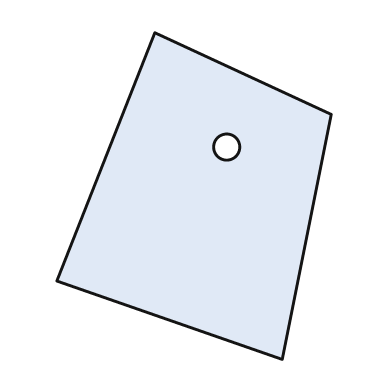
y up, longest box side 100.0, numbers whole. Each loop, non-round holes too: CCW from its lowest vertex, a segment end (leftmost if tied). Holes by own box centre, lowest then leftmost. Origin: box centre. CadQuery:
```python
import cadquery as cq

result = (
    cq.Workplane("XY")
    .moveTo(27.0, -50.0)
    .lineTo(42.0, 25.0)
    .lineTo(-12.0, 50.0)
    .lineTo(-42.0, -26.0)
    .close()
    .moveTo(10.0, 15.0)
    .circle(4.0)
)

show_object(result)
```